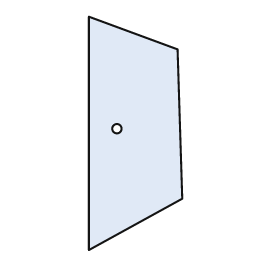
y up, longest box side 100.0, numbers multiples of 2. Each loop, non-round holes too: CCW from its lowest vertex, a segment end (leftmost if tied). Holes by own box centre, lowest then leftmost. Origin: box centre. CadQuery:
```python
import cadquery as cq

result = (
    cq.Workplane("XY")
    .moveTo(-20.0, -50.0)
    .lineTo(20.0, -28.0)
    .lineTo(18.0, 36.0)
    .lineTo(-20.0, 50.0)
    .close()
    .moveTo(-8.0, 2.0)
    .circle(2.0)
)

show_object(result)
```